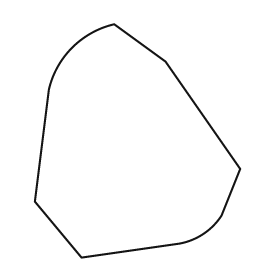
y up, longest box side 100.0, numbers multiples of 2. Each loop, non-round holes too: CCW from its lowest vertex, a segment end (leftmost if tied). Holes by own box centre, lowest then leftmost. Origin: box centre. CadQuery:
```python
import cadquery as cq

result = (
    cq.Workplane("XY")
    .moveTo(-24.0, -50.0)
    .lineTo(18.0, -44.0)
    .threePointArc((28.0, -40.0), (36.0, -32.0))
    .lineTo(44.0, -12.0)
    .lineTo(12.0, 34.0)
    .lineTo(-10.0, 50.0)
    .threePointArc((-28.0, 40.0), (-38.0, 22.0))
    .lineTo(-44.0, -26.0)
    .close()
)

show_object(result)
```